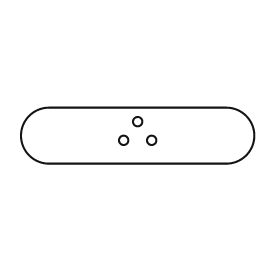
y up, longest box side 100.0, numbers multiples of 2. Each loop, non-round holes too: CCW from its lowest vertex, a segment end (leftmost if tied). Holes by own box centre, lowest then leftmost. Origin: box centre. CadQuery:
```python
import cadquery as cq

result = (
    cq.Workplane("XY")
    .moveTo(-38.0, -12.0)
    .lineTo(38.0, -12.0)
    .threePointArc((50.0, 0.0), (38.0, 12.0))
    .lineTo(-38.0, 12.0)
    .threePointArc((-50.0, 0.0), (-38.0, -12.0))
    .close()
    .moveTo(-6.0, -2.0)
    .circle(2.0)
    .moveTo(6.0, -2.0)
    .circle(2.0)
    .moveTo(0.0, 6.0)
    .circle(2.0)
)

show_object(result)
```